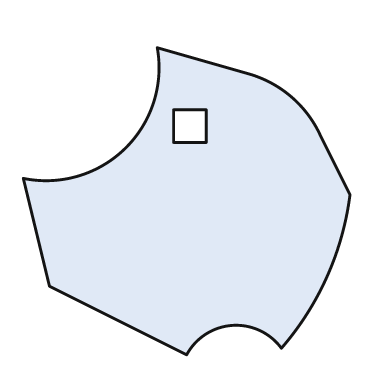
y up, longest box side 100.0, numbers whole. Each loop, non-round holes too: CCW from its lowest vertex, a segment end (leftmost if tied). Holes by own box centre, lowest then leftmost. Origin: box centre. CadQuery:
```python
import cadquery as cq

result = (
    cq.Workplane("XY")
    .moveTo(0.0, -47.0)
    .threePointArc((14.0, -38.0), (29.0, -45.0))
    .threePointArc((43.0, -23.0), (50.0, 2.0))
    .lineTo(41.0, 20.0)
    .threePointArc((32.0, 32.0), (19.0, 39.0))
    .lineTo(-9.0, 47.0)
    .threePointArc((-19.0, 16.0), (-50.0, 7.0))
    .lineTo(-42.0, -26.0)
    .close()
    .moveTo(-4.0, 18.0)
    .lineTo(6.0, 18.0)
    .lineTo(6.0, 28.0)
    .lineTo(-4.0, 28.0)
    .close()
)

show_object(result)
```